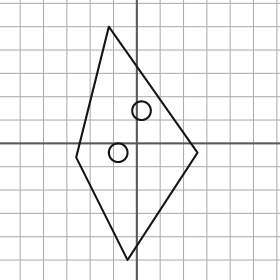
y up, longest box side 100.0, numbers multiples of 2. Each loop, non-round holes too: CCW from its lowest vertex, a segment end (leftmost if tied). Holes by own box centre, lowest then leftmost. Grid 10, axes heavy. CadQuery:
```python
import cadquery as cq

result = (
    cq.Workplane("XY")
    .moveTo(-4.0, -50.0)
    .lineTo(26.0, -4.0)
    .lineTo(-12.0, 50.0)
    .lineTo(-26.0, -6.0)
    .close()
    .moveTo(-8.0, -4.0)
    .circle(4.0)
    .moveTo(2.0, 14.0)
    .circle(4.0)
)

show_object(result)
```